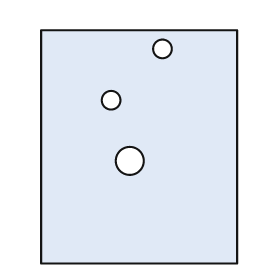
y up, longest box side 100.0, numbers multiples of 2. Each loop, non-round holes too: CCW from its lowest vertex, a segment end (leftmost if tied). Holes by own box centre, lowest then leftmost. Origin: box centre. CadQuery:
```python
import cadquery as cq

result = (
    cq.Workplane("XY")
    .moveTo(-42.0, -50.0)
    .lineTo(42.0, -50.0)
    .lineTo(42.0, 50.0)
    .lineTo(-42.0, 50.0)
    .close()
    .moveTo(-4.0, -6.0)
    .circle(6.0)
    .moveTo(-12.0, 20.0)
    .circle(4.0)
    .moveTo(10.0, 42.0)
    .circle(4.0)
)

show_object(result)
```